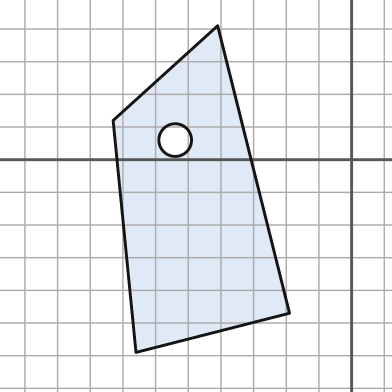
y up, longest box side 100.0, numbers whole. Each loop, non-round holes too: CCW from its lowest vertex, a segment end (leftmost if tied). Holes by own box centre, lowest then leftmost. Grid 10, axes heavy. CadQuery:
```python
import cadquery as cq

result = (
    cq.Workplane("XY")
    .moveTo(-66.0, -59.0)
    .lineTo(-19.0, -47.0)
    .lineTo(-41.0, 41.0)
    .lineTo(-73.0, 12.0)
    .close()
    .moveTo(-54.0, 6.0)
    .circle(5.0)
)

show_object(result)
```